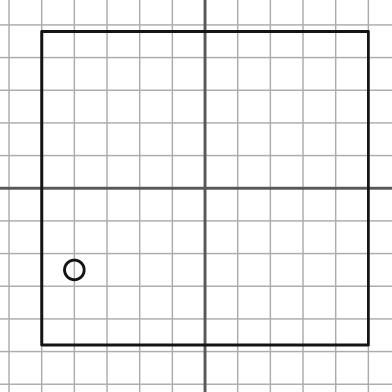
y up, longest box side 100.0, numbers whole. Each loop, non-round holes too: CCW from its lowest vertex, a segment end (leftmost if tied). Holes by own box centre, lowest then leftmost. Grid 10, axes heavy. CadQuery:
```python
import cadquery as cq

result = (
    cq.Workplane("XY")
    .moveTo(-50.0, -48.0)
    .lineTo(50.0, -48.0)
    .lineTo(50.0, 48.0)
    .lineTo(-50.0, 48.0)
    .close()
    .moveTo(-40.0, -25.0)
    .circle(3.0)
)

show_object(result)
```